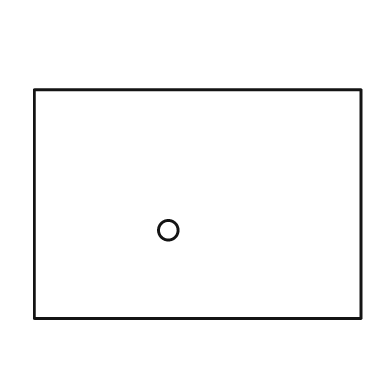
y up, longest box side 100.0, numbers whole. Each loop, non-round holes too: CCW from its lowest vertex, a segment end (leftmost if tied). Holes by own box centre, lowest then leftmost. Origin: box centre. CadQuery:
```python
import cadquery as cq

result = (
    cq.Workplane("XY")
    .moveTo(-50.0, -35.0)
    .lineTo(50.0, -35.0)
    .lineTo(50.0, 35.0)
    .lineTo(-50.0, 35.0)
    .close()
    .moveTo(-9.0, -8.0)
    .circle(3.0)
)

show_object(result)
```